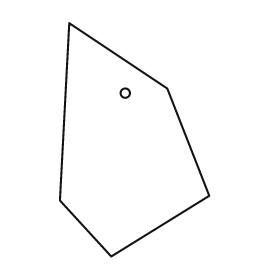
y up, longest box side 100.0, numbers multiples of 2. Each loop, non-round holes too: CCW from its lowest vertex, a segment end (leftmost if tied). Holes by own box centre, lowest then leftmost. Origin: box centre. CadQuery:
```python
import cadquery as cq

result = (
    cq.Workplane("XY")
    .moveTo(-10.0, -50.0)
    .lineTo(32.0, -24.0)
    .lineTo(14.0, 22.0)
    .lineTo(-28.0, 50.0)
    .lineTo(-32.0, -26.0)
    .close()
    .moveTo(-4.0, 20.0)
    .circle(2.0)
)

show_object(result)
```